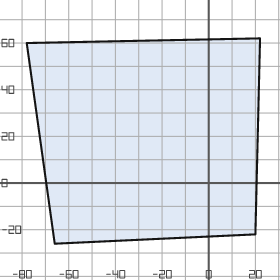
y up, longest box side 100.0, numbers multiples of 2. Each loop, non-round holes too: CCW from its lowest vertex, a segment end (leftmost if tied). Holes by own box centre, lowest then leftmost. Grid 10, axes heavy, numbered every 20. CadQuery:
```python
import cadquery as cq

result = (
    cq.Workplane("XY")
    .moveTo(-66.0, -26.0)
    .lineTo(20.0, -22.0)
    .lineTo(22.0, 62.0)
    .lineTo(-78.0, 60.0)
    .close()
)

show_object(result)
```